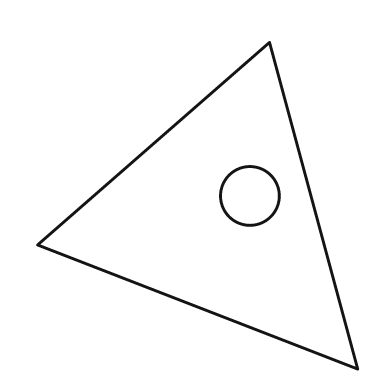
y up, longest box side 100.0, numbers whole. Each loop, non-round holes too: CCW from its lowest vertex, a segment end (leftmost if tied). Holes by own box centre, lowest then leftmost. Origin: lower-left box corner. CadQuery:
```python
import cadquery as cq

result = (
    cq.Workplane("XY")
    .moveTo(98.0, 0.0)
    .lineTo(71.0, 100.0)
    .lineTo(0.0, 38.0)
    .close()
    .moveTo(65.0, 53.0)
    .circle(9.0)
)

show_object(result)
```